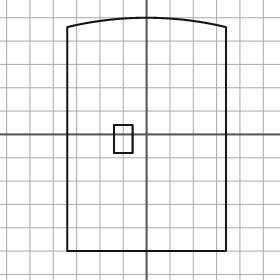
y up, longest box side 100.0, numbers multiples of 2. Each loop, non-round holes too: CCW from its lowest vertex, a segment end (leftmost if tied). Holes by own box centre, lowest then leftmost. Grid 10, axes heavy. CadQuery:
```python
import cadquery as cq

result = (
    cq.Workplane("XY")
    .moveTo(-34.0, -50.0)
    .lineTo(34.0, -50.0)
    .lineTo(34.0, 46.0)
    .threePointArc((0.0, 50.0), (-34.0, 46.0))
    .close()
    .moveTo(-14.0, -8.0)
    .lineTo(-6.0, -8.0)
    .lineTo(-6.0, 4.0)
    .lineTo(-14.0, 4.0)
    .close()
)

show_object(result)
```